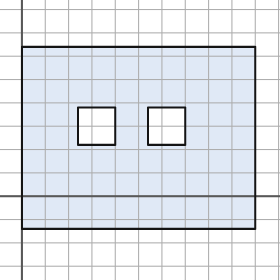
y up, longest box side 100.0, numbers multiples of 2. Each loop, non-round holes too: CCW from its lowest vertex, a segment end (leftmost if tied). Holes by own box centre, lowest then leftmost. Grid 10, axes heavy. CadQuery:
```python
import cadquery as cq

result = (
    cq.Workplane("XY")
    .moveTo(0.0, -14.0)
    .lineTo(100.0, -14.0)
    .lineTo(100.0, 64.0)
    .lineTo(0.0, 64.0)
    .close()
    .moveTo(24.0, 22.0)
    .lineTo(40.0, 22.0)
    .lineTo(40.0, 38.0)
    .lineTo(24.0, 38.0)
    .close()
    .moveTo(54.0, 22.0)
    .lineTo(70.0, 22.0)
    .lineTo(70.0, 38.0)
    .lineTo(54.0, 38.0)
    .close()
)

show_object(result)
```